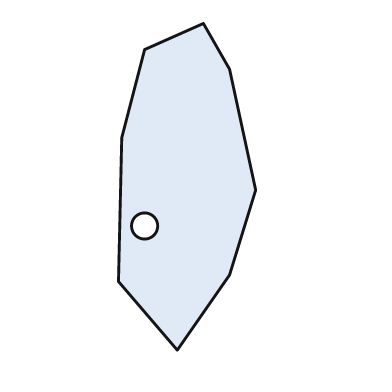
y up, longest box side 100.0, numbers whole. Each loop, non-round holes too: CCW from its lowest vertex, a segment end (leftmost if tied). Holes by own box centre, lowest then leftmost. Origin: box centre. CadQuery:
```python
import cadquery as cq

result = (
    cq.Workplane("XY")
    .moveTo(-3.0, -50.0)
    .lineTo(13.0, -27.0)
    .lineTo(21.0, -1.0)
    .lineTo(13.0, 36.0)
    .lineTo(5.0, 50.0)
    .lineTo(-13.0, 42.0)
    .lineTo(-20.0, 15.0)
    .lineTo(-21.0, -29.0)
    .close()
    .moveTo(-13.0, -12.0)
    .circle(4.0)
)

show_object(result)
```